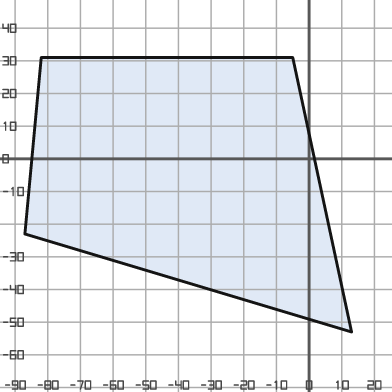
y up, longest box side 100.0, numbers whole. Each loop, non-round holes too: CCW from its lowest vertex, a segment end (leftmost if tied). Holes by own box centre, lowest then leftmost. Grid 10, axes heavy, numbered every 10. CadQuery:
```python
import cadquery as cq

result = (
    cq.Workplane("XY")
    .moveTo(13.0, -53.0)
    .lineTo(-5.0, 31.0)
    .lineTo(-82.0, 31.0)
    .lineTo(-87.0, -23.0)
    .close()
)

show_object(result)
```